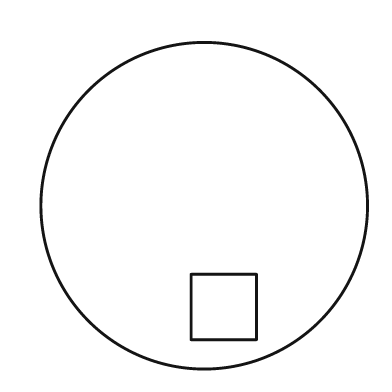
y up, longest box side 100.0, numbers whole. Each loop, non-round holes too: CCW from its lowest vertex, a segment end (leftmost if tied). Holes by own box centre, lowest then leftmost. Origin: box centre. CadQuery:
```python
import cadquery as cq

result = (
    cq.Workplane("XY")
    .moveTo(0.0, 0.0)
    .circle(50.0)
    .moveTo(-4.0, -41.0)
    .lineTo(16.0, -41.0)
    .lineTo(16.0, -21.0)
    .lineTo(-4.0, -21.0)
    .close()
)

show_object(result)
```